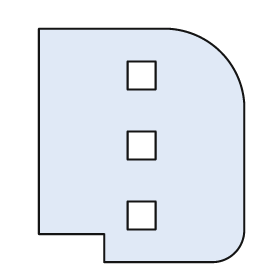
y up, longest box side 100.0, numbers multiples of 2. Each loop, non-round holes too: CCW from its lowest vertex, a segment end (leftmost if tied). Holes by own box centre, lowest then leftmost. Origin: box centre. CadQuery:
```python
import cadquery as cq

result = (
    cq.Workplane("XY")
    .moveTo(-16.0, -50.0)
    .lineTo(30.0, -50.0)
    .threePointArc((40.0, -46.0), (44.0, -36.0))
    .lineTo(44.0, 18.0)
    .threePointArc((34.0, 40.0), (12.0, 50.0))
    .lineTo(-44.0, 50.0)
    .lineTo(-44.0, -38.0)
    .lineTo(-16.0, -38.0)
    .close()
    .moveTo(-6.0, -36.0)
    .lineTo(6.0, -36.0)
    .lineTo(6.0, -24.0)
    .lineTo(-6.0, -24.0)
    .close()
    .moveTo(-6.0, -6.0)
    .lineTo(6.0, -6.0)
    .lineTo(6.0, 6.0)
    .lineTo(-6.0, 6.0)
    .close()
    .moveTo(-6.0, 24.0)
    .lineTo(6.0, 24.0)
    .lineTo(6.0, 36.0)
    .lineTo(-6.0, 36.0)
    .close()
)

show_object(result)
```